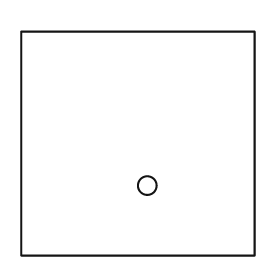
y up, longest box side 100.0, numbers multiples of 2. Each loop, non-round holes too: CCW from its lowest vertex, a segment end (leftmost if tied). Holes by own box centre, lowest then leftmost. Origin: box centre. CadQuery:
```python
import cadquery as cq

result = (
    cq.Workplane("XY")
    .moveTo(-50.0, -48.0)
    .lineTo(50.0, -48.0)
    .lineTo(50.0, 48.0)
    .lineTo(-50.0, 48.0)
    .close()
    .moveTo(4.0, -18.0)
    .circle(4.0)
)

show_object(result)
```